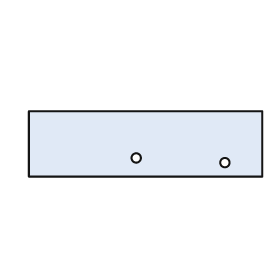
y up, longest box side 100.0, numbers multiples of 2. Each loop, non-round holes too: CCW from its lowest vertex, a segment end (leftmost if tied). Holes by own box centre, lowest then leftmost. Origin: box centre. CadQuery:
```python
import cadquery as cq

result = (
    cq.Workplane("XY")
    .moveTo(-50.0, -14.0)
    .lineTo(50.0, -14.0)
    .lineTo(50.0, 14.0)
    .lineTo(-50.0, 14.0)
    .close()
    .moveTo(34.0, -8.0)
    .circle(2.0)
    .moveTo(-4.0, -6.0)
    .circle(2.0)
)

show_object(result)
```